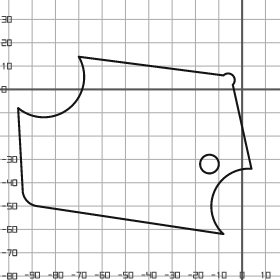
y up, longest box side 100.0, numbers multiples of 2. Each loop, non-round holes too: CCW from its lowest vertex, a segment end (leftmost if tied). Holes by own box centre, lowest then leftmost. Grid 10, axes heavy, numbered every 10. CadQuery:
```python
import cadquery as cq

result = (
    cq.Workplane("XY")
    .moveTo(-8.0, -62.0)
    .threePointArc((-12.0, -44.0), (4.0, -34.0))
    .lineTo(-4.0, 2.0)
    .threePointArc((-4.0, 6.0), (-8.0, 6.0))
    .lineTo(-70.0, 14.0)
    .threePointArc((-74.0, -8.0), (-96.0, -8.0))
    .lineTo(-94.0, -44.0)
    .threePointArc((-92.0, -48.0), (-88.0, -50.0))
    .close()
    .moveTo(-14.0, -32.0)
    .circle(4.0)
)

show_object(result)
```